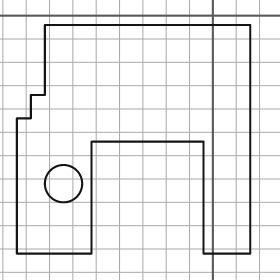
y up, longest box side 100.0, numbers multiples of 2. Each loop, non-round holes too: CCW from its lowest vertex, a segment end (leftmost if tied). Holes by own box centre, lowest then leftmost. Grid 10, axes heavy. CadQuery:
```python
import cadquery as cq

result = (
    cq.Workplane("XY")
    .moveTo(-84.0, -102.0)
    .lineTo(-52.0, -102.0)
    .lineTo(-52.0, -54.0)
    .lineTo(-4.0, -54.0)
    .lineTo(-4.0, -102.0)
    .lineTo(16.0, -102.0)
    .lineTo(16.0, -4.0)
    .lineTo(-72.0, -4.0)
    .lineTo(-72.0, -34.0)
    .lineTo(-78.0, -34.0)
    .lineTo(-78.0, -44.0)
    .lineTo(-84.0, -44.0)
    .close()
    .moveTo(-64.0, -72.0)
    .circle(8.0)
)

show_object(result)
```